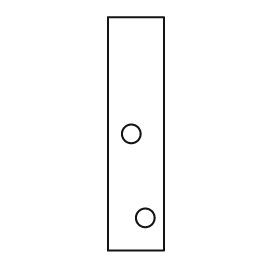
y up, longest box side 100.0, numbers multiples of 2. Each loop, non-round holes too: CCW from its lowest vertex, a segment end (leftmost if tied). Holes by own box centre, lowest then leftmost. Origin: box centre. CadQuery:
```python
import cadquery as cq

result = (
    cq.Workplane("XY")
    .moveTo(-12.0, -50.0)
    .lineTo(12.0, -50.0)
    .lineTo(12.0, 50.0)
    .lineTo(-12.0, 50.0)
    .close()
    .moveTo(4.0, -36.0)
    .circle(4.0)
    .moveTo(-2.0, 0.0)
    .circle(4.0)
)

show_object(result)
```